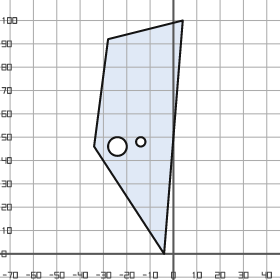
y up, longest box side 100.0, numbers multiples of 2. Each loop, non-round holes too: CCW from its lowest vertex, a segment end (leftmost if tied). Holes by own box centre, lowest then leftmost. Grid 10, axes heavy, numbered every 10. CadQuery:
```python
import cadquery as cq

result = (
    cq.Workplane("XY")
    .moveTo(-4.0, 0.0)
    .lineTo(4.0, 100.0)
    .lineTo(-28.0, 92.0)
    .lineTo(-34.0, 46.0)
    .close()
    .moveTo(-24.0, 46.0)
    .circle(4.0)
    .moveTo(-14.0, 48.0)
    .circle(2.0)
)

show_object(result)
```